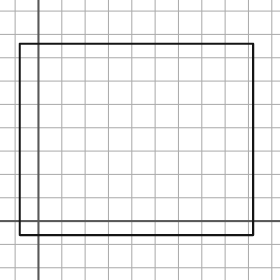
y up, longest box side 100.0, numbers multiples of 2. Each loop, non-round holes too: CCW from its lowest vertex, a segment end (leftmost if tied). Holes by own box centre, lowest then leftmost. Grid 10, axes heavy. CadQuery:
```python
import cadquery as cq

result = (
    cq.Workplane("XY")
    .moveTo(-8.0, -6.0)
    .lineTo(92.0, -6.0)
    .lineTo(92.0, 76.0)
    .lineTo(-8.0, 76.0)
    .close()
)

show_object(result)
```